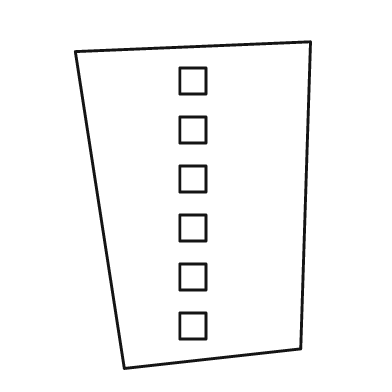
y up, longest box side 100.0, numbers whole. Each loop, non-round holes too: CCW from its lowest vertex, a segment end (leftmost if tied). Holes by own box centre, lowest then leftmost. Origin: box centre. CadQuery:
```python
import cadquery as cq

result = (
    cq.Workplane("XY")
    .moveTo(-21.0, -50.0)
    .lineTo(33.0, -44.0)
    .lineTo(36.0, 50.0)
    .lineTo(-36.0, 47.0)
    .close()
    .moveTo(-4.0, -41.0)
    .lineTo(4.0, -41.0)
    .lineTo(4.0, -33.0)
    .lineTo(-4.0, -33.0)
    .close()
    .moveTo(-4.0, -26.0)
    .lineTo(4.0, -26.0)
    .lineTo(4.0, -18.0)
    .lineTo(-4.0, -18.0)
    .close()
    .moveTo(-4.0, -11.0)
    .lineTo(4.0, -11.0)
    .lineTo(4.0, -3.0)
    .lineTo(-4.0, -3.0)
    .close()
    .moveTo(-4.0, 4.0)
    .lineTo(4.0, 4.0)
    .lineTo(4.0, 12.0)
    .lineTo(-4.0, 12.0)
    .close()
    .moveTo(-4.0, 19.0)
    .lineTo(4.0, 19.0)
    .lineTo(4.0, 27.0)
    .lineTo(-4.0, 27.0)
    .close()
    .moveTo(-4.0, 34.0)
    .lineTo(4.0, 34.0)
    .lineTo(4.0, 42.0)
    .lineTo(-4.0, 42.0)
    .close()
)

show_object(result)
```